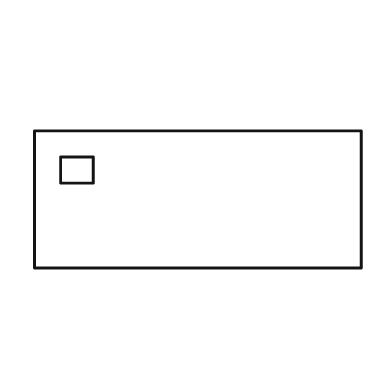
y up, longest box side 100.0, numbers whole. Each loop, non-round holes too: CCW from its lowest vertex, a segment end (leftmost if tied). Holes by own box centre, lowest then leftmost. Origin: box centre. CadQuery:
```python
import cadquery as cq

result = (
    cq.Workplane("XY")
    .moveTo(-50.0, -21.0)
    .lineTo(50.0, -21.0)
    .lineTo(50.0, 21.0)
    .lineTo(-50.0, 21.0)
    .close()
    .moveTo(-42.0, 5.0)
    .lineTo(-32.0, 5.0)
    .lineTo(-32.0, 13.0)
    .lineTo(-42.0, 13.0)
    .close()
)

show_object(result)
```